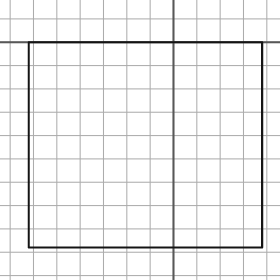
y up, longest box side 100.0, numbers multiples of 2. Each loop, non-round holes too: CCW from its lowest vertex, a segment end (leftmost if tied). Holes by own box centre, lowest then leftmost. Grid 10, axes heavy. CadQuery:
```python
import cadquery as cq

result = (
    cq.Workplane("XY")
    .moveTo(-62.0, -88.0)
    .lineTo(38.0, -88.0)
    .lineTo(38.0, 0.0)
    .lineTo(-62.0, 0.0)
    .close()
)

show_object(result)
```